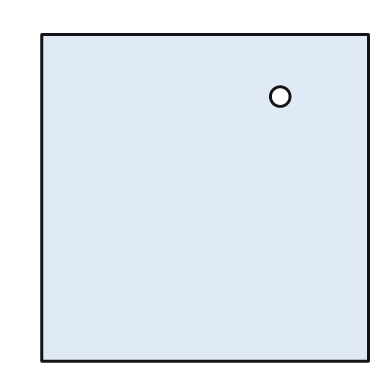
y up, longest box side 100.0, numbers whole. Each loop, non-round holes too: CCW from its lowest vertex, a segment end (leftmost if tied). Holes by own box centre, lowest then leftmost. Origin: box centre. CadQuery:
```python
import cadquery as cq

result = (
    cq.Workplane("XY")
    .moveTo(-50.0, -50.0)
    .lineTo(50.0, -50.0)
    .lineTo(50.0, 50.0)
    .lineTo(-50.0, 50.0)
    .close()
    .moveTo(23.0, 31.0)
    .circle(3.0)
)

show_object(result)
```